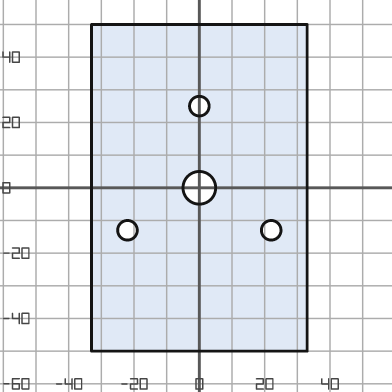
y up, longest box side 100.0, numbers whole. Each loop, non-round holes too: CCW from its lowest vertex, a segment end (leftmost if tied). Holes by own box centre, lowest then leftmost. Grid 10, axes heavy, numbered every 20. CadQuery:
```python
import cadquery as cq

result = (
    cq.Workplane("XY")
    .moveTo(-33.0, -50.0)
    .lineTo(33.0, -50.0)
    .lineTo(33.0, 50.0)
    .lineTo(-33.0, 50.0)
    .close()
    .moveTo(-22.0, -13.0)
    .circle(3.0)
    .moveTo(22.0, -13.0)
    .circle(3.0)
    .moveTo(0.0, 0.0)
    .circle(5.0)
    .moveTo(0.0, 25.0)
    .circle(3.0)
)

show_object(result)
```